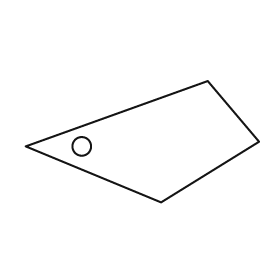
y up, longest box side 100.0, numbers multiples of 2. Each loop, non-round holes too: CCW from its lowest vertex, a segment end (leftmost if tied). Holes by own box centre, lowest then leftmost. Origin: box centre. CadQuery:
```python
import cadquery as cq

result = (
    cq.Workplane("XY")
    .moveTo(8.0, -26.0)
    .lineTo(50.0, 0.0)
    .lineTo(28.0, 26.0)
    .lineTo(-50.0, -2.0)
    .close()
    .moveTo(-26.0, -2.0)
    .circle(4.0)
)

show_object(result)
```